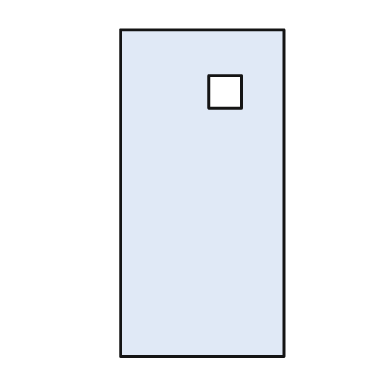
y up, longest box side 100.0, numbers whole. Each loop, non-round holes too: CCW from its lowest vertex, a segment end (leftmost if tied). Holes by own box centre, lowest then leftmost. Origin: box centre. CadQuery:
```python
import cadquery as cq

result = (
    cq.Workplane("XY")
    .moveTo(-25.0, -50.0)
    .lineTo(25.0, -50.0)
    .lineTo(25.0, 50.0)
    .lineTo(-25.0, 50.0)
    .close()
    .moveTo(2.0, 26.0)
    .lineTo(12.0, 26.0)
    .lineTo(12.0, 36.0)
    .lineTo(2.0, 36.0)
    .close()
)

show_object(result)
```